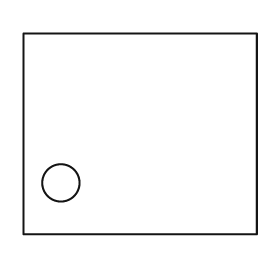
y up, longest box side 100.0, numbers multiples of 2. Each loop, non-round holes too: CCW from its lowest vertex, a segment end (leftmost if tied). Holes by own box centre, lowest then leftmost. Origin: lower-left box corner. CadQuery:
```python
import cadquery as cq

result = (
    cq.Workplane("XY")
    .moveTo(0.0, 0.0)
    .lineTo(100.0, 0.0)
    .lineTo(100.0, 86.0)
    .lineTo(0.0, 86.0)
    .close()
    .moveTo(16.0, 22.0)
    .circle(8.0)
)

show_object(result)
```